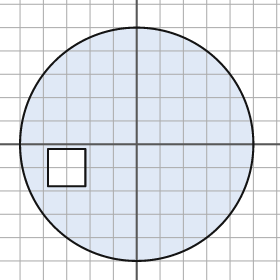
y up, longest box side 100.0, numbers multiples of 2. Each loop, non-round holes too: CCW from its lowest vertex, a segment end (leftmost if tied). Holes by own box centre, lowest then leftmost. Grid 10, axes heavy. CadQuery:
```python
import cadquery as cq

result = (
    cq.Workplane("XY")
    .moveTo(0.0, 0.0)
    .circle(50.0)
    .moveTo(-38.0, -18.0)
    .lineTo(-22.0, -18.0)
    .lineTo(-22.0, -2.0)
    .lineTo(-38.0, -2.0)
    .close()
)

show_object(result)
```